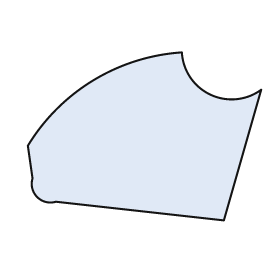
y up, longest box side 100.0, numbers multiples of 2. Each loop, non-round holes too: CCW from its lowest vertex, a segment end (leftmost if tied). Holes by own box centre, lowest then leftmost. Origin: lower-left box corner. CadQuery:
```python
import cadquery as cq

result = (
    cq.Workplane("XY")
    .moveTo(84.0, 0.0)
    .lineTo(100.0, 56.0)
    .threePointArc((78.0, 54.0), (66.0, 72.0))
    .threePointArc((28.0, 60.0), (0.0, 32.0))
    .lineTo(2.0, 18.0)
    .threePointArc((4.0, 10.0), (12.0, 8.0))
    .close()
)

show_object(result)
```